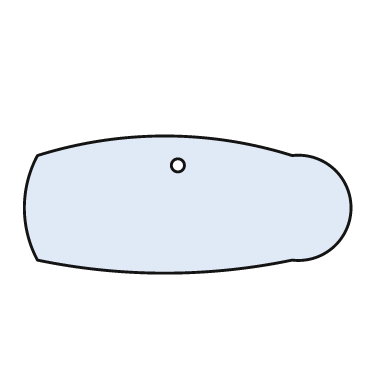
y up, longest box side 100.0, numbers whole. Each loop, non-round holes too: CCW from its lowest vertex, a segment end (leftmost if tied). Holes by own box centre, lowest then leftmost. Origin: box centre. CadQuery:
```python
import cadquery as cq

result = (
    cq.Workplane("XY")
    .moveTo(-46.0, -17.0)
    .threePointArc((-7.0, -21.0), (32.0, -17.0))
    .threePointArc((50.0, -1.0), (32.0, 15.0))
    .threePointArc((-7.0, 21.0), (-46.0, 15.0))
    .threePointArc((-50.0, -1.0), (-46.0, -17.0))
    .close()
    .moveTo(-3.0, 12.0)
    .circle(2.0)
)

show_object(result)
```